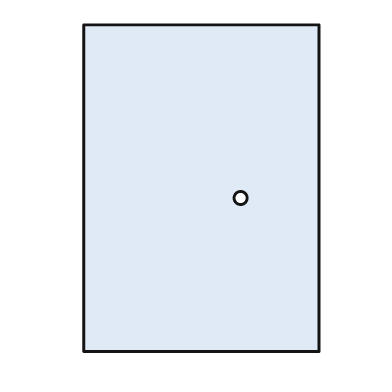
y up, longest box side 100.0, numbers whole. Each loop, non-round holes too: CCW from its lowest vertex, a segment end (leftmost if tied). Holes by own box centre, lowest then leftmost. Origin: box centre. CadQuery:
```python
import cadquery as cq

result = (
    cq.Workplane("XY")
    .moveTo(-36.0, -50.0)
    .lineTo(36.0, -50.0)
    .lineTo(36.0, 50.0)
    .lineTo(-36.0, 50.0)
    .close()
    .moveTo(12.0, -3.0)
    .circle(2.0)
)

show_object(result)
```